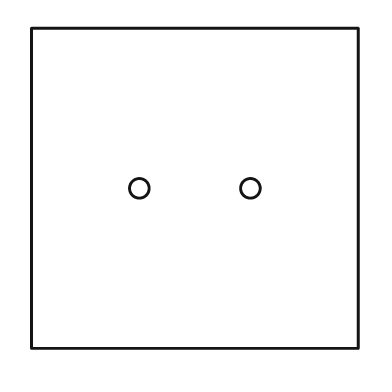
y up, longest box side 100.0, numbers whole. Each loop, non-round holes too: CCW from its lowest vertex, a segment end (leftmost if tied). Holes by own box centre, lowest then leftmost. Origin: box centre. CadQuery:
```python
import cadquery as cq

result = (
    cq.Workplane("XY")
    .moveTo(-50.0, -49.0)
    .lineTo(50.0, -49.0)
    .lineTo(50.0, 49.0)
    .lineTo(-50.0, 49.0)
    .close()
    .moveTo(-17.0, 0.0)
    .circle(3.0)
    .moveTo(17.0, 0.0)
    .circle(3.0)
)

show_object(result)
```